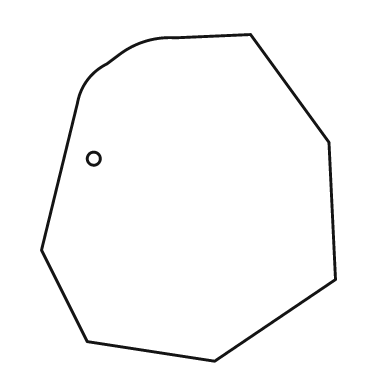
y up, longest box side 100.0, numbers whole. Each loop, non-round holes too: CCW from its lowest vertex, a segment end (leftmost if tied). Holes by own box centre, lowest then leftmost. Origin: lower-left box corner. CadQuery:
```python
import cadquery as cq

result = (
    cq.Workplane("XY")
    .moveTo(53.0, 0.0)
    .lineTo(90.0, 25.0)
    .lineTo(88.0, 67.0)
    .lineTo(64.0, 100.0)
    .lineTo(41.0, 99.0)
    .threePointArc((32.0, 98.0), (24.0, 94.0))
    .lineTo(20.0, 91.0)
    .threePointArc((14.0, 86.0), (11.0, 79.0))
    .lineTo(0.0, 34.0)
    .lineTo(14.0, 6.0)
    .close()
    .moveTo(16.0, 62.0)
    .circle(2.0)
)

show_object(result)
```